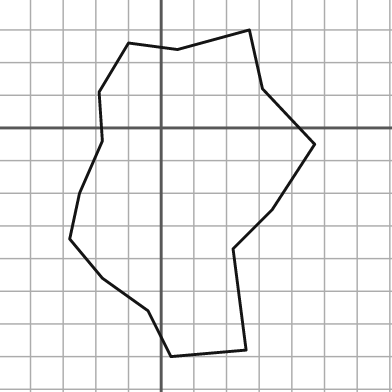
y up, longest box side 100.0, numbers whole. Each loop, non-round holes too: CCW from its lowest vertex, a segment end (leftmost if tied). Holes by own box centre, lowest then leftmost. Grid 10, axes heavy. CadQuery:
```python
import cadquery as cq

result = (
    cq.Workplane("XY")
    .moveTo(3.0, -70.0)
    .lineTo(26.0, -68.0)
    .lineTo(22.0, -37.0)
    .lineTo(34.0, -25.0)
    .lineTo(47.0, -5.0)
    .lineTo(31.0, 12.0)
    .lineTo(27.0, 30.0)
    .lineTo(5.0, 24.0)
    .lineTo(-10.0, 26.0)
    .lineTo(-19.0, 11.0)
    .lineTo(-18.0, -4.0)
    .lineTo(-25.0, -20.0)
    .lineTo(-28.0, -34.0)
    .lineTo(-18.0, -46.0)
    .lineTo(-4.0, -56.0)
    .close()
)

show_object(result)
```